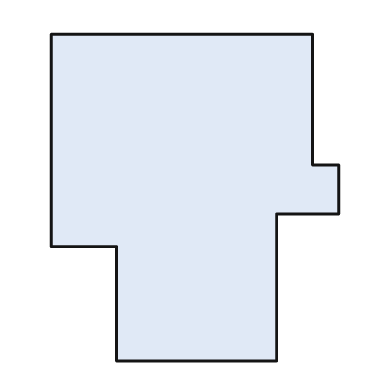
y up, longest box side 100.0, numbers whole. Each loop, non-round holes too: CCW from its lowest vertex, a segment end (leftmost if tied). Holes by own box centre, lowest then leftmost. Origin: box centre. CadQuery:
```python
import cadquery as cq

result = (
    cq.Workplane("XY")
    .moveTo(-24.0, -50.0)
    .lineTo(25.0, -50.0)
    .lineTo(25.0, -5.0)
    .lineTo(44.0, -5.0)
    .lineTo(44.0, 10.0)
    .lineTo(36.0, 10.0)
    .lineTo(36.0, 50.0)
    .lineTo(-44.0, 50.0)
    .lineTo(-44.0, -15.0)
    .lineTo(-24.0, -15.0)
    .close()
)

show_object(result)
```